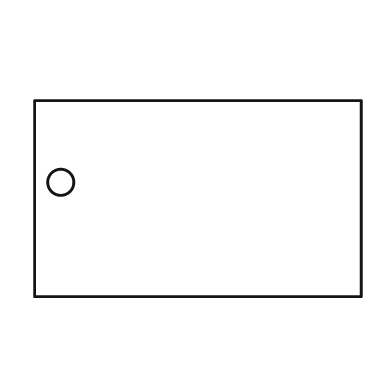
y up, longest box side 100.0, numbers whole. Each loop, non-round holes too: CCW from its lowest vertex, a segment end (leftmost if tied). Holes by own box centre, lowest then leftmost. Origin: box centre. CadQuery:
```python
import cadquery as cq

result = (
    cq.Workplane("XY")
    .moveTo(-50.0, -30.0)
    .lineTo(50.0, -30.0)
    .lineTo(50.0, 30.0)
    .lineTo(-50.0, 30.0)
    .close()
    .moveTo(-42.0, 5.0)
    .circle(4.0)
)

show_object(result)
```